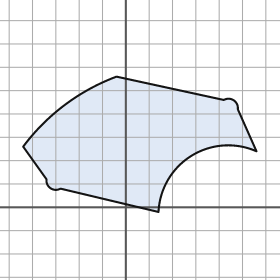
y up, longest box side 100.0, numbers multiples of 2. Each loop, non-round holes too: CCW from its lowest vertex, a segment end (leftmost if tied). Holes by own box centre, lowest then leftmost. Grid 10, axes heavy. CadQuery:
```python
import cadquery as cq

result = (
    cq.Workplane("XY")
    .moveTo(14.0, -2.0)
    .threePointArc((28.0, 22.0), (56.0, 24.0))
    .lineTo(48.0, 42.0)
    .threePointArc((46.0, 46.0), (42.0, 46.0))
    .lineTo(-4.0, 56.0)
    .threePointArc((-26.0, 44.0), (-44.0, 26.0))
    .lineTo(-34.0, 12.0)
    .threePointArc((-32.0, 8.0), (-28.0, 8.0))
    .close()
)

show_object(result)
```